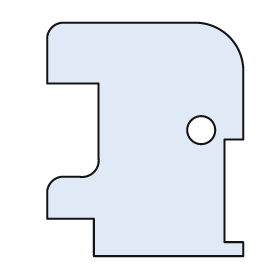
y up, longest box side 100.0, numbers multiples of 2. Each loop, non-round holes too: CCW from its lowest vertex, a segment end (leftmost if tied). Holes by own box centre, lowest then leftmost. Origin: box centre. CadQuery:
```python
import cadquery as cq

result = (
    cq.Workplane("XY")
    .moveTo(-22.0, -50.0)
    .lineTo(42.0, -50.0)
    .lineTo(42.0, -44.0)
    .lineTo(34.0, -44.0)
    .lineTo(34.0, 0.0)
    .lineTo(42.0, 0.0)
    .lineTo(42.0, 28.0)
    .threePointArc((36.0, 44.0), (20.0, 50.0))
    .lineTo(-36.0, 50.0)
    .threePointArc((-40.0, 48.0), (-42.0, 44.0))
    .lineTo(-42.0, 24.0)
    .lineTo(-20.0, 24.0)
    .lineTo(-20.0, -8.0)
    .threePointArc((-22.0, -14.0), (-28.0, -16.0))
    .lineTo(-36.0, -16.0)
    .threePointArc((-40.0, -18.0), (-42.0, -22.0))
    .lineTo(-42.0, -34.0)
    .lineTo(-22.0, -34.0)
    .close()
    .moveTo(24.0, 4.0)
    .circle(6.0)
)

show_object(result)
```